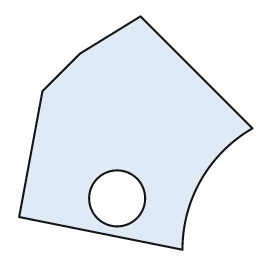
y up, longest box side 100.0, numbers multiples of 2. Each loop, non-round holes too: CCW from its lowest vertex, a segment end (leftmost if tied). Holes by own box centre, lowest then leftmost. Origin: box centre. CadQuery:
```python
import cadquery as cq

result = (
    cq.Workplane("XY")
    .moveTo(20.0, -50.0)
    .threePointArc((28.0, -20.0), (50.0, 2.0))
    .lineTo(2.0, 50.0)
    .lineTo(-24.0, 34.0)
    .lineTo(-40.0, 18.0)
    .lineTo(-50.0, -36.0)
    .close()
    .moveTo(-8.0, -28.0)
    .circle(12.0)
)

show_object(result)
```